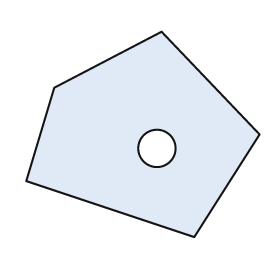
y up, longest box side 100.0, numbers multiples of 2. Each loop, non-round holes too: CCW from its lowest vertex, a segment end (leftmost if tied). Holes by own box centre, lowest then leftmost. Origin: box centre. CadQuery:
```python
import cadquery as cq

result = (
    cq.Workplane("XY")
    .moveTo(22.0, -44.0)
    .lineTo(50.0, 0.0)
    .lineTo(8.0, 44.0)
    .lineTo(-38.0, 20.0)
    .lineTo(-50.0, -20.0)
    .close()
    .moveTo(6.0, -6.0)
    .circle(8.0)
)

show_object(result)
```